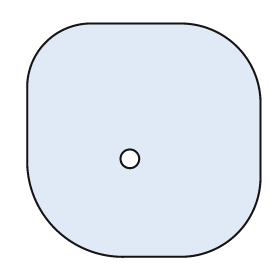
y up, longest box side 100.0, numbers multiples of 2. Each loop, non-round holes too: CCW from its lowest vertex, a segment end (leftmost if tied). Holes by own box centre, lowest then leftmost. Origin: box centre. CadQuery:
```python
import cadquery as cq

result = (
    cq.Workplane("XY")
    .moveTo(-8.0, -50.0)
    .lineTo(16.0, -50.0)
    .threePointArc((40.0, -40.0), (50.0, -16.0))
    .lineTo(50.0, 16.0)
    .threePointArc((40.0, 40.0), (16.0, 50.0))
    .lineTo(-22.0, 50.0)
    .threePointArc((-42.0, 42.0), (-50.0, 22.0))
    .lineTo(-50.0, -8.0)
    .threePointArc((-38.0, -38.0), (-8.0, -50.0))
    .close()
    .moveTo(-6.0, -8.0)
    .circle(4.0)
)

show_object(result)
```